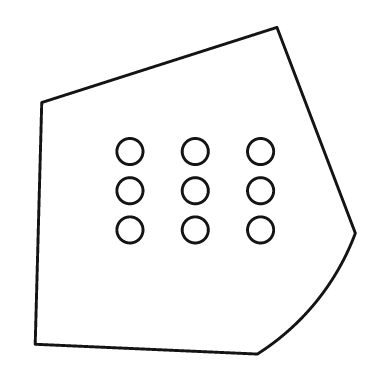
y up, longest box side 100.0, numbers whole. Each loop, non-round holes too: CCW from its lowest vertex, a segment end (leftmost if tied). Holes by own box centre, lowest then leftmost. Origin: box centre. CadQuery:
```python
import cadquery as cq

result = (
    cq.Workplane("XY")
    .moveTo(19.0, -50.0)
    .threePointArc((37.0, -34.0), (49.0, -13.0))
    .lineTo(25.0, 50.0)
    .lineTo(-47.0, 27.0)
    .lineTo(-49.0, -47.0)
    .close()
    .moveTo(-20.0, -12.0)
    .circle(4.0)
    .moveTo(0.0, -12.0)
    .circle(4.0)
    .moveTo(20.0, -12.0)
    .circle(4.0)
    .moveTo(-20.0, 0.0)
    .circle(4.0)
    .moveTo(0.0, 0.0)
    .circle(4.0)
    .moveTo(20.0, 0.0)
    .circle(4.0)
    .moveTo(-20.0, 12.0)
    .circle(4.0)
    .moveTo(0.0, 12.0)
    .circle(4.0)
    .moveTo(20.0, 12.0)
    .circle(4.0)
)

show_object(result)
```